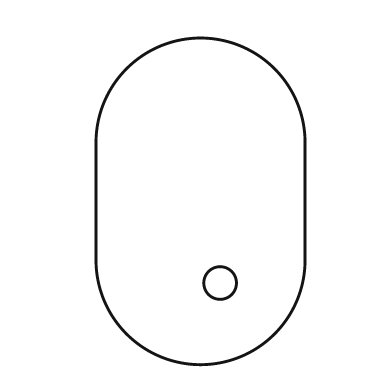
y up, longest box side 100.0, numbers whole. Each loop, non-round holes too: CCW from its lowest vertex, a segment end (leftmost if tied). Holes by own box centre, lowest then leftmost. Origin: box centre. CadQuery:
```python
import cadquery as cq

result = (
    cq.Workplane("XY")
    .moveTo(-32.0, -18.0)
    .threePointArc((0.0, -50.0), (32.0, -18.0))
    .lineTo(32.0, 18.0)
    .threePointArc((0.0, 50.0), (-32.0, 18.0))
    .close()
    .moveTo(6.0, -25.0)
    .circle(5.0)
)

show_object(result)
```